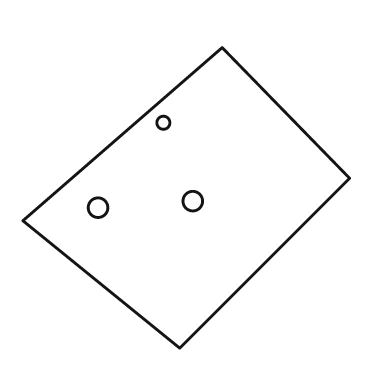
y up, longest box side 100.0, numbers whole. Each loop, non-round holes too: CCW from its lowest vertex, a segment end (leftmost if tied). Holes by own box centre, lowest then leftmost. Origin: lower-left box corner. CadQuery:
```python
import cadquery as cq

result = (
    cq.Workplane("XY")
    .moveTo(48.0, 0.0)
    .lineTo(100.0, 52.0)
    .lineTo(61.0, 92.0)
    .lineTo(0.0, 39.0)
    .close()
    .moveTo(23.0, 43.0)
    .circle(3.0)
    .moveTo(52.0, 45.0)
    .circle(3.0)
    .moveTo(43.0, 69.0)
    .circle(2.0)
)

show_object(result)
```